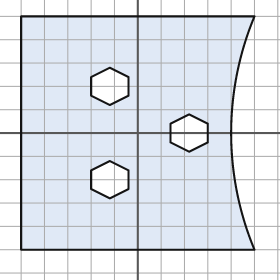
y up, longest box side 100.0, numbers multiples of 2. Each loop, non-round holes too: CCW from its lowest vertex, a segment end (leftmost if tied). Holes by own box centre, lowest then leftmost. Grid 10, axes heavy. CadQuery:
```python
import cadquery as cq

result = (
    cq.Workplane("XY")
    .moveTo(-50.0, -50.0)
    .lineTo(50.0, -50.0)
    .threePointArc((40.0, 0.0), (50.0, 50.0))
    .lineTo(-50.0, 50.0)
    .close()
    .moveTo(-12.0, -28.0)
    .lineTo(-4.0, -24.0)
    .lineTo(-4.0, -16.0)
    .lineTo(-12.0, -12.0)
    .lineTo(-20.0, -16.0)
    .lineTo(-20.0, -24.0)
    .close()
    .moveTo(22.0, -8.0)
    .lineTo(30.0, -4.0)
    .lineTo(30.0, 4.0)
    .lineTo(22.0, 8.0)
    .lineTo(14.0, 4.0)
    .lineTo(14.0, -4.0)
    .close()
    .moveTo(-12.0, 12.0)
    .lineTo(-4.0, 16.0)
    .lineTo(-4.0, 24.0)
    .lineTo(-12.0, 28.0)
    .lineTo(-20.0, 24.0)
    .lineTo(-20.0, 16.0)
    .close()
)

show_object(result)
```